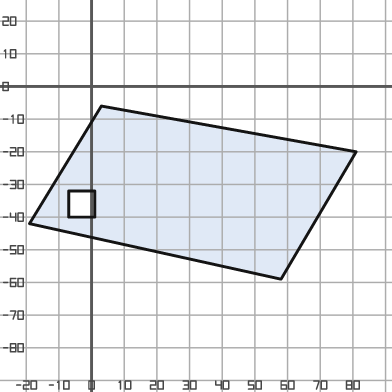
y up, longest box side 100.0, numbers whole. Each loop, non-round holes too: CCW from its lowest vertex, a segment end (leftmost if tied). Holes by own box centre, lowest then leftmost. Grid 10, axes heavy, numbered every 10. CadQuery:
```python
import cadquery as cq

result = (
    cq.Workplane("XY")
    .moveTo(58.0, -59.0)
    .lineTo(81.0, -20.0)
    .lineTo(3.0, -6.0)
    .lineTo(-19.0, -42.0)
    .close()
    .moveTo(-7.0, -40.0)
    .lineTo(1.0, -40.0)
    .lineTo(1.0, -32.0)
    .lineTo(-7.0, -32.0)
    .close()
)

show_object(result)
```